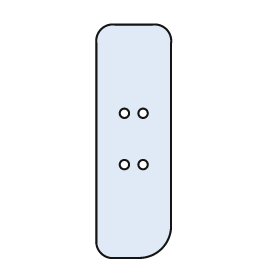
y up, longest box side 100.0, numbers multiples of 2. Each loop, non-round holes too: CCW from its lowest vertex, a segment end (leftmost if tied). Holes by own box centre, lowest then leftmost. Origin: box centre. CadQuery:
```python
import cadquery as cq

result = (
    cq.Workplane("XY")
    .moveTo(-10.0, -50.0)
    .lineTo(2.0, -50.0)
    .threePointArc((12.0, -46.0), (16.0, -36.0))
    .lineTo(16.0, 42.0)
    .threePointArc((14.0, 48.0), (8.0, 50.0))
    .lineTo(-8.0, 50.0)
    .threePointArc((-14.0, 48.0), (-16.0, 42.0))
    .lineTo(-16.0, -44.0)
    .threePointArc((-14.0, -48.0), (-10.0, -50.0))
    .close()
    .moveTo(-4.0, -10.0)
    .circle(2.0)
    .moveTo(4.0, -10.0)
    .circle(2.0)
    .moveTo(-4.0, 12.0)
    .circle(2.0)
    .moveTo(4.0, 12.0)
    .circle(2.0)
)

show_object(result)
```